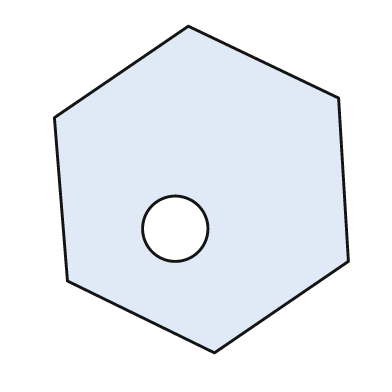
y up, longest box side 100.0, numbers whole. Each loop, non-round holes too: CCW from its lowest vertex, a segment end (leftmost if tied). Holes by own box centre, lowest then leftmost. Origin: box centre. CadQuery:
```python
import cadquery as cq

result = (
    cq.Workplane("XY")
    .moveTo(4.0, -50.0)
    .lineTo(45.0, -22.0)
    .lineTo(42.0, 28.0)
    .lineTo(-4.0, 50.0)
    .lineTo(-45.0, 22.0)
    .lineTo(-41.0, -28.0)
    .close()
    .moveTo(-8.0, -12.0)
    .circle(10.0)
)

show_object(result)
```